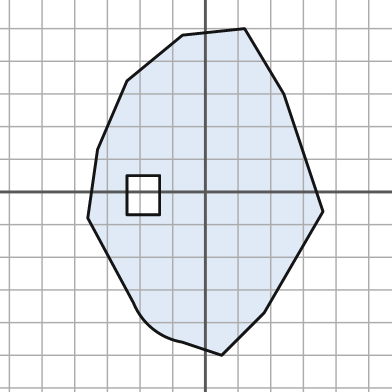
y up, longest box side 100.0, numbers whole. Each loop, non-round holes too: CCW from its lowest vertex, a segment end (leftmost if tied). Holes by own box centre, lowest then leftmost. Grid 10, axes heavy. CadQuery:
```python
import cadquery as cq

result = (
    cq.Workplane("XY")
    .moveTo(5.0, -50.0)
    .lineTo(18.0, -37.0)
    .lineTo(36.0, -6.0)
    .lineTo(24.0, 30.0)
    .lineTo(12.0, 50.0)
    .lineTo(-7.0, 48.0)
    .lineTo(-24.0, 34.0)
    .lineTo(-33.0, 13.0)
    .lineTo(-36.0, -8.0)
    .lineTo(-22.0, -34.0)
    .threePointArc((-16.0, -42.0), (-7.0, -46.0))
    .close()
    .moveTo(-24.0, -7.0)
    .lineTo(-14.0, -7.0)
    .lineTo(-14.0, 5.0)
    .lineTo(-24.0, 5.0)
    .close()
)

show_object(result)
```